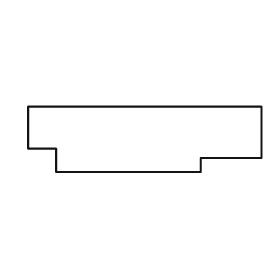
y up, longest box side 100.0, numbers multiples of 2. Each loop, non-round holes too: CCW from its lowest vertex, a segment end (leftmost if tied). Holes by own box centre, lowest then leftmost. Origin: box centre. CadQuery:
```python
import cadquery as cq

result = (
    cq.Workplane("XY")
    .moveTo(-38.0, -14.0)
    .lineTo(24.0, -14.0)
    .lineTo(24.0, -8.0)
    .lineTo(50.0, -8.0)
    .lineTo(50.0, 14.0)
    .lineTo(-50.0, 14.0)
    .lineTo(-50.0, -4.0)
    .lineTo(-38.0, -4.0)
    .close()
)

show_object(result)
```